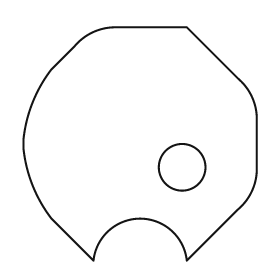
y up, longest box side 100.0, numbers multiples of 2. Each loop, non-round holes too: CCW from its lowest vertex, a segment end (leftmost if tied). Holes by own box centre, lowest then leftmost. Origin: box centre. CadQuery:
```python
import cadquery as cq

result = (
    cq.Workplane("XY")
    .moveTo(-20.0, -50.0)
    .threePointArc((0.0, -32.0), (20.0, -50.0))
    .lineTo(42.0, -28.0)
    .threePointArc((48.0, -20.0), (50.0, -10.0))
    .lineTo(50.0, 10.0)
    .threePointArc((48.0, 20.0), (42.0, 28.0))
    .lineTo(20.0, 50.0)
    .lineTo(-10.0, 50.0)
    .threePointArc((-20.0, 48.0), (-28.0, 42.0))
    .lineTo(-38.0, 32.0)
    .threePointArc((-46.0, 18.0), (-50.0, 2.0))
    .lineTo(-50.0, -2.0)
    .threePointArc((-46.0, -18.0), (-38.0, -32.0))
    .close()
    .moveTo(18.0, -10.0)
    .circle(10.0)
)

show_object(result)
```